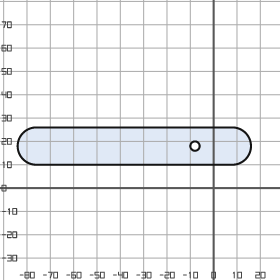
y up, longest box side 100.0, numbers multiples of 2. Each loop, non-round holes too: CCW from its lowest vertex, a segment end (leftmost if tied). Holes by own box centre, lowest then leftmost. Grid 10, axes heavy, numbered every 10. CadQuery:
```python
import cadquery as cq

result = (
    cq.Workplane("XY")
    .moveTo(-76.0, 10.0)
    .lineTo(8.0, 10.0)
    .threePointArc((16.0, 18.0), (8.0, 26.0))
    .lineTo(-76.0, 26.0)
    .threePointArc((-84.0, 18.0), (-76.0, 10.0))
    .close()
    .moveTo(-8.0, 18.0)
    .circle(2.0)
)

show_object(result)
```